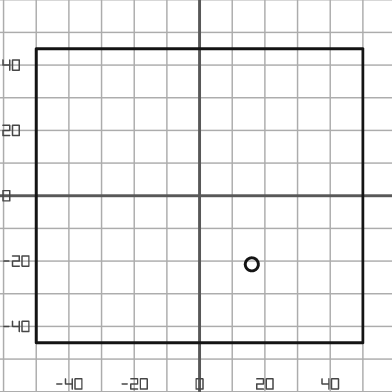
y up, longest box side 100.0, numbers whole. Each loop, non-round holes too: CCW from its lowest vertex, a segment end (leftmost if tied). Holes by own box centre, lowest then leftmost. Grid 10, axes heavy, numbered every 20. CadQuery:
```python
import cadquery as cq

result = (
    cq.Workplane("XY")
    .moveTo(-50.0, -45.0)
    .lineTo(50.0, -45.0)
    .lineTo(50.0, 45.0)
    .lineTo(-50.0, 45.0)
    .close()
    .moveTo(16.0, -21.0)
    .circle(2.0)
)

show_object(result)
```